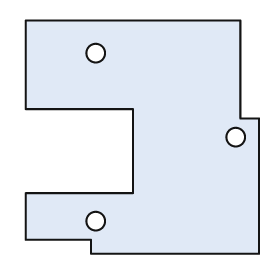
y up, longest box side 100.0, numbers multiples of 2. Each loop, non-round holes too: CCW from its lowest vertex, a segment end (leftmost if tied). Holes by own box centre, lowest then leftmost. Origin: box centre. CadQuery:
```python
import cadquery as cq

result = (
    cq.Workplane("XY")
    .moveTo(-22.0, -50.0)
    .lineTo(50.0, -50.0)
    .lineTo(50.0, 8.0)
    .lineTo(42.0, 8.0)
    .lineTo(42.0, 50.0)
    .lineTo(-50.0, 50.0)
    .lineTo(-50.0, 12.0)
    .lineTo(-4.0, 12.0)
    .lineTo(-4.0, -24.0)
    .lineTo(-50.0, -24.0)
    .lineTo(-50.0, -44.0)
    .lineTo(-22.0, -44.0)
    .close()
    .moveTo(-20.0, -36.0)
    .circle(4.0)
    .moveTo(40.0, 0.0)
    .circle(4.0)
    .moveTo(-20.0, 36.0)
    .circle(4.0)
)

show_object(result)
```